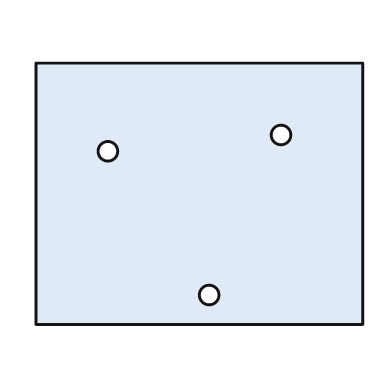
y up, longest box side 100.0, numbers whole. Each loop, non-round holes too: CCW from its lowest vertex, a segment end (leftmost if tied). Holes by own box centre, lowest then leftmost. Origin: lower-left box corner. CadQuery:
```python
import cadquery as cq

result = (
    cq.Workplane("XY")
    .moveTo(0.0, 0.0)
    .lineTo(100.0, 0.0)
    .lineTo(100.0, 80.0)
    .lineTo(0.0, 80.0)
    .close()
    .moveTo(53.0, 9.0)
    .circle(3.0)
    .moveTo(22.0, 53.0)
    .circle(3.0)
    .moveTo(75.0, 58.0)
    .circle(3.0)
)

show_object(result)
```